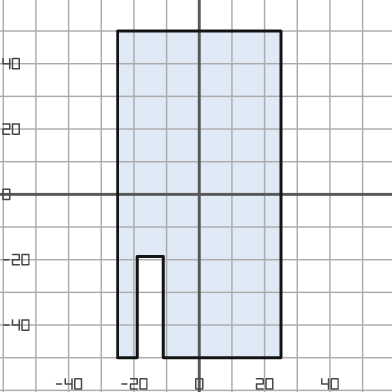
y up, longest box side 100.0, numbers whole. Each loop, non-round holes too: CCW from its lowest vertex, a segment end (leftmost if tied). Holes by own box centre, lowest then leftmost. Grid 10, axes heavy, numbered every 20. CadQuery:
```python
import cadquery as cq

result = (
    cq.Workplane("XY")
    .moveTo(-25.0, -50.0)
    .lineTo(-19.0, -50.0)
    .lineTo(-19.0, -19.0)
    .lineTo(-11.0, -19.0)
    .lineTo(-11.0, -50.0)
    .lineTo(25.0, -50.0)
    .lineTo(25.0, 50.0)
    .lineTo(-25.0, 50.0)
    .close()
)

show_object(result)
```